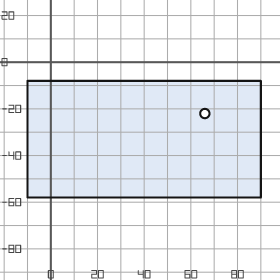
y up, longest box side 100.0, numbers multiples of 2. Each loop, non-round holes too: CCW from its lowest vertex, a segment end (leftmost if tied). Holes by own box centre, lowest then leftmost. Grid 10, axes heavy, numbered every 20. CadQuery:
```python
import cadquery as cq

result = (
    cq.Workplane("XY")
    .moveTo(-10.0, -58.0)
    .lineTo(90.0, -58.0)
    .lineTo(90.0, -8.0)
    .lineTo(-10.0, -8.0)
    .close()
    .moveTo(66.0, -22.0)
    .circle(2.0)
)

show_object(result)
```